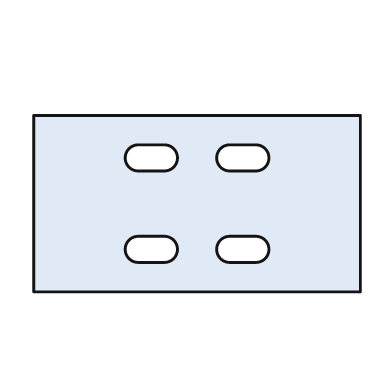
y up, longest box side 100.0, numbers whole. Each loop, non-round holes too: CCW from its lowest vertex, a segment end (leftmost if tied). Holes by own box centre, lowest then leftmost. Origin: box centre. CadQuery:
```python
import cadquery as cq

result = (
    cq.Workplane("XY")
    .moveTo(-50.0, -27.0)
    .lineTo(50.0, -27.0)
    .lineTo(50.0, 27.0)
    .lineTo(-50.0, 27.0)
    .close()
    .moveTo(-18.0, -18.0)
    .lineTo(-10.0, -18.0)
    .threePointArc((-6.0, -14.0), (-10.0, -10.0))
    .lineTo(-18.0, -10.0)
    .threePointArc((-22.0, -14.0), (-18.0, -18.0))
    .close()
    .moveTo(10.0, -18.0)
    .lineTo(18.0, -18.0)
    .threePointArc((22.0, -14.0), (18.0, -10.0))
    .lineTo(10.0, -10.0)
    .threePointArc((6.0, -14.0), (10.0, -18.0))
    .close()
    .moveTo(-18.0, 10.0)
    .lineTo(-10.0, 10.0)
    .threePointArc((-6.0, 14.0), (-10.0, 18.0))
    .lineTo(-18.0, 18.0)
    .threePointArc((-22.0, 14.0), (-18.0, 10.0))
    .close()
    .moveTo(10.0, 10.0)
    .lineTo(18.0, 10.0)
    .threePointArc((22.0, 14.0), (18.0, 18.0))
    .lineTo(10.0, 18.0)
    .threePointArc((6.0, 14.0), (10.0, 10.0))
    .close()
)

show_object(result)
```